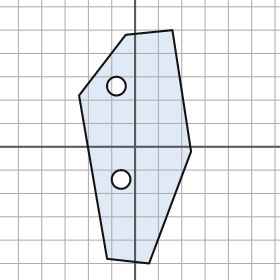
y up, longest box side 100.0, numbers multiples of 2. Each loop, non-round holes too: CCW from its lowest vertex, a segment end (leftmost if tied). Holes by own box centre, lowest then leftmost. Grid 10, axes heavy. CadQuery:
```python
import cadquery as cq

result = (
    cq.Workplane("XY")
    .moveTo(6.0, -50.0)
    .lineTo(24.0, -2.0)
    .lineTo(16.0, 50.0)
    .lineTo(-4.0, 48.0)
    .lineTo(-24.0, 22.0)
    .lineTo(-12.0, -48.0)
    .close()
    .moveTo(-6.0, -14.0)
    .circle(4.0)
    .moveTo(-8.0, 26.0)
    .circle(4.0)
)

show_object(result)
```